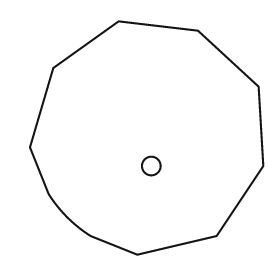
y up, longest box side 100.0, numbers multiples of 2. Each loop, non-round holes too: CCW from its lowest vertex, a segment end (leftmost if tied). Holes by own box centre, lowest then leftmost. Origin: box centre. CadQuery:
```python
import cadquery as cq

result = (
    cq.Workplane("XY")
    .moveTo(-4.0, -50.0)
    .lineTo(30.0, -42.0)
    .lineTo(50.0, -12.0)
    .lineTo(48.0, 22.0)
    .lineTo(22.0, 46.0)
    .lineTo(-12.0, 50.0)
    .lineTo(-40.0, 30.0)
    .lineTo(-50.0, -4.0)
    .lineTo(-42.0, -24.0)
    .threePointArc((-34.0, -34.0), (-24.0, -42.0))
    .close()
    .moveTo(2.0, -12.0)
    .circle(4.0)
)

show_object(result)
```